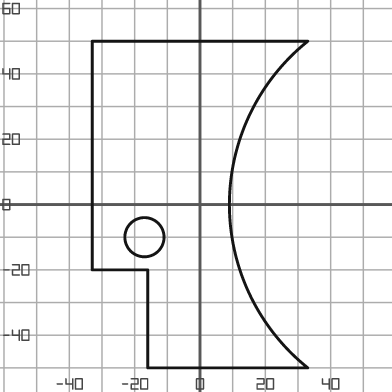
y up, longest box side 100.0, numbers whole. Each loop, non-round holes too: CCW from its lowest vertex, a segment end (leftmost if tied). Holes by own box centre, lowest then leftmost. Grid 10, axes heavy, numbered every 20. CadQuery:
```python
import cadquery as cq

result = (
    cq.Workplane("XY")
    .moveTo(-16.0, -50.0)
    .lineTo(33.0, -50.0)
    .threePointArc((9.0, 0.0), (33.0, 50.0))
    .lineTo(-33.0, 50.0)
    .lineTo(-33.0, -20.0)
    .lineTo(-16.0, -20.0)
    .close()
    .moveTo(-17.0, -10.0)
    .circle(6.0)
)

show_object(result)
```